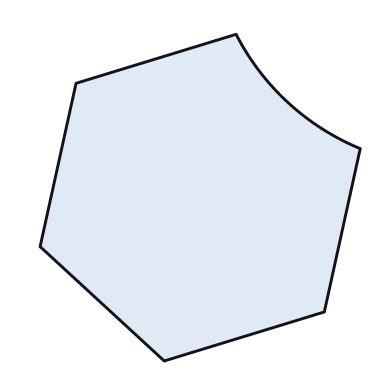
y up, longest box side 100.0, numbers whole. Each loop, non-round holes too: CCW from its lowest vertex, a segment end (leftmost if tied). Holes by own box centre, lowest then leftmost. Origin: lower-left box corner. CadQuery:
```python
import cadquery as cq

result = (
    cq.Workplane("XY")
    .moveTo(38.0, 0.0)
    .lineTo(87.0, 15.0)
    .lineTo(98.0, 65.0)
    .threePointArc((76.0, 79.0), (60.0, 100.0))
    .lineTo(11.0, 85.0)
    .lineTo(0.0, 35.0)
    .close()
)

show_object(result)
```